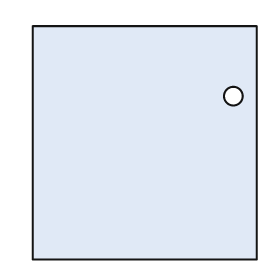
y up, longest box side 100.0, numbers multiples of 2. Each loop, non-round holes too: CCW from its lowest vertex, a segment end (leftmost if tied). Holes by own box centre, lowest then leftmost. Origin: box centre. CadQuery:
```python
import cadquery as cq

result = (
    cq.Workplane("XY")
    .moveTo(-48.0, -50.0)
    .lineTo(48.0, -50.0)
    .lineTo(48.0, 50.0)
    .lineTo(-48.0, 50.0)
    .close()
    .moveTo(38.0, 20.0)
    .circle(4.0)
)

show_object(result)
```